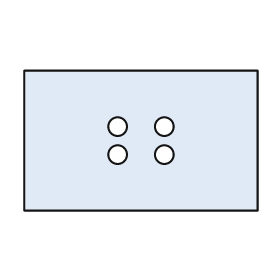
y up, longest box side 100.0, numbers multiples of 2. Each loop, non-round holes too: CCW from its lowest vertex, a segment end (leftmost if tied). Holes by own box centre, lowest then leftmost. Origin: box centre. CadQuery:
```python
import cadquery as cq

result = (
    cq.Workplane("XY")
    .moveTo(-50.0, -30.0)
    .lineTo(50.0, -30.0)
    .lineTo(50.0, 30.0)
    .lineTo(-50.0, 30.0)
    .close()
    .moveTo(-10.0, -6.0)
    .circle(4.0)
    .moveTo(10.0, -6.0)
    .circle(4.0)
    .moveTo(-10.0, 6.0)
    .circle(4.0)
    .moveTo(10.0, 6.0)
    .circle(4.0)
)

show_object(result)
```